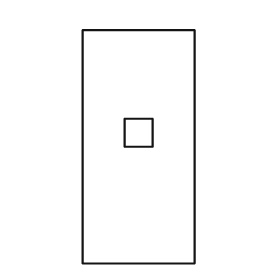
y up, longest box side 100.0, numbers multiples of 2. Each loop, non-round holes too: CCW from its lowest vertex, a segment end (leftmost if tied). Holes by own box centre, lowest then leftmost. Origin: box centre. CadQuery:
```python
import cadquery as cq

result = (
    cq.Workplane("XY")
    .moveTo(-24.0, -50.0)
    .lineTo(24.0, -50.0)
    .lineTo(24.0, 50.0)
    .lineTo(-24.0, 50.0)
    .close()
    .moveTo(-6.0, 0.0)
    .lineTo(6.0, 0.0)
    .lineTo(6.0, 12.0)
    .lineTo(-6.0, 12.0)
    .close()
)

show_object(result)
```